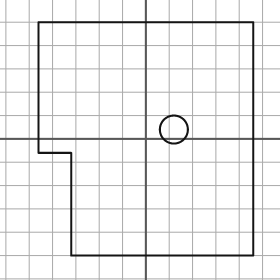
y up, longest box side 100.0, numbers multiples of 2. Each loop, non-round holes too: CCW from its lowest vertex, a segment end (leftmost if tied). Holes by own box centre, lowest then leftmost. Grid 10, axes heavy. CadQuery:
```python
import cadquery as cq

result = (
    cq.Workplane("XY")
    .moveTo(-32.0, -50.0)
    .lineTo(46.0, -50.0)
    .lineTo(46.0, 50.0)
    .lineTo(-46.0, 50.0)
    .lineTo(-46.0, -6.0)
    .lineTo(-32.0, -6.0)
    .close()
    .moveTo(12.0, 4.0)
    .circle(6.0)
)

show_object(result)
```